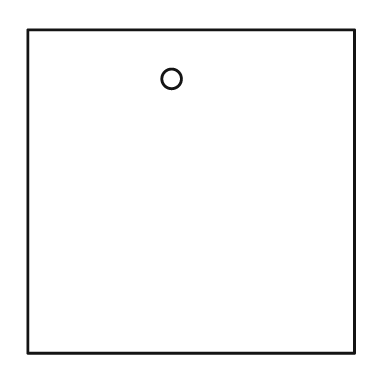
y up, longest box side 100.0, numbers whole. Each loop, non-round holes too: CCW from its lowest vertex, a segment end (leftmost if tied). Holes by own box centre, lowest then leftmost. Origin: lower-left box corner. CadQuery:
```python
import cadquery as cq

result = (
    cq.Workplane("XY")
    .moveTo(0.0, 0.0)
    .lineTo(100.0, 0.0)
    .lineTo(100.0, 99.0)
    .lineTo(0.0, 99.0)
    .close()
    .moveTo(44.0, 84.0)
    .circle(3.0)
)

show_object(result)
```